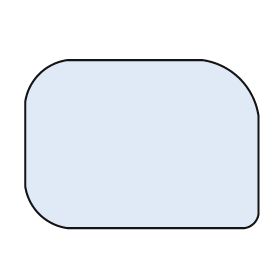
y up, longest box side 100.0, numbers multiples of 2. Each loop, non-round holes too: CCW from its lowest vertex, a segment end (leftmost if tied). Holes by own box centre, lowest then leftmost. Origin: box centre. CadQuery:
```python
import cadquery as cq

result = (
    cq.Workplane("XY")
    .moveTo(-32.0, -36.0)
    .lineTo(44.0, -36.0)
    .threePointArc((48.0, -34.0), (50.0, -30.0))
    .lineTo(50.0, 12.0)
    .threePointArc((42.0, 28.0), (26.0, 36.0))
    .lineTo(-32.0, 36.0)
    .threePointArc((-44.0, 30.0), (-50.0, 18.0))
    .lineTo(-50.0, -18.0)
    .threePointArc((-44.0, -30.0), (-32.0, -36.0))
    .close()
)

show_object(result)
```